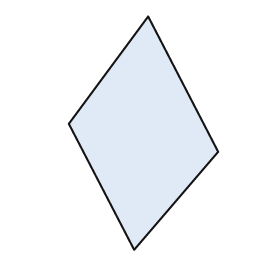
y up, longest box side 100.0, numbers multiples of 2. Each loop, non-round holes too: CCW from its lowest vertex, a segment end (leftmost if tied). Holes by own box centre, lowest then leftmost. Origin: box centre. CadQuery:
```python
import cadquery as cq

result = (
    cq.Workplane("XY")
    .moveTo(-4.0, -50.0)
    .lineTo(32.0, -8.0)
    .lineTo(2.0, 50.0)
    .lineTo(-32.0, 4.0)
    .close()
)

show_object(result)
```